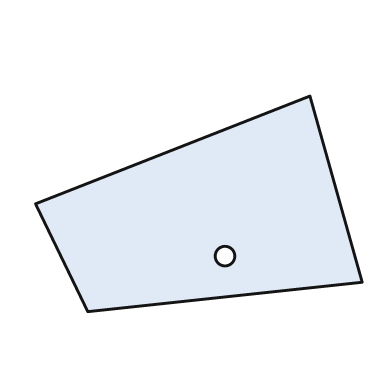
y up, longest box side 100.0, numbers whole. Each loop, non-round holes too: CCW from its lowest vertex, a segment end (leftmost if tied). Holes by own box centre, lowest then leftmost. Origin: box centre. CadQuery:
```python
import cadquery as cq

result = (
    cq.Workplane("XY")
    .moveTo(-34.0, -33.0)
    .lineTo(50.0, -24.0)
    .lineTo(34.0, 33.0)
    .lineTo(-50.0, 0.0)
    .close()
    .moveTo(8.0, -16.0)
    .circle(3.0)
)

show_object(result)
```